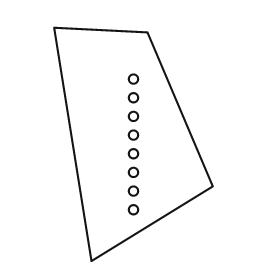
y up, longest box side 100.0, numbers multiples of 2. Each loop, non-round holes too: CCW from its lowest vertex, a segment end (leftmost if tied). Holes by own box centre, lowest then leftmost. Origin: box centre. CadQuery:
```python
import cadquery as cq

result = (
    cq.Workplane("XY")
    .moveTo(-18.0, -50.0)
    .lineTo(34.0, -18.0)
    .lineTo(6.0, 48.0)
    .lineTo(-34.0, 50.0)
    .close()
    .moveTo(0.0, -28.0)
    .circle(2.0)
    .moveTo(0.0, -20.0)
    .circle(2.0)
    .moveTo(0.0, -12.0)
    .circle(2.0)
    .moveTo(0.0, -4.0)
    .circle(2.0)
    .moveTo(0.0, 4.0)
    .circle(2.0)
    .moveTo(0.0, 12.0)
    .circle(2.0)
    .moveTo(0.0, 20.0)
    .circle(2.0)
    .moveTo(0.0, 28.0)
    .circle(2.0)
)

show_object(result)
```